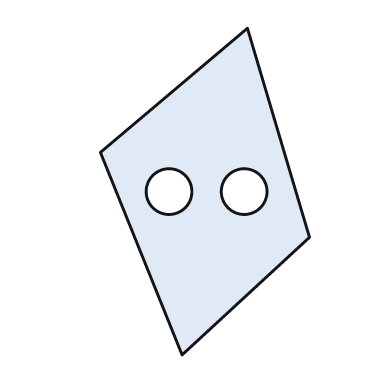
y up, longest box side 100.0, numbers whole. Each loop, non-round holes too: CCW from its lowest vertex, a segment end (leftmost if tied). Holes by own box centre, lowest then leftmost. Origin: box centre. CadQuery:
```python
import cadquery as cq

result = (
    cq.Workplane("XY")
    .moveTo(-7.0, -50.0)
    .lineTo(32.0, -14.0)
    .lineTo(13.0, 50.0)
    .lineTo(-32.0, 12.0)
    .close()
    .moveTo(-11.0, 0.0)
    .circle(7.0)
    .moveTo(12.0, 0.0)
    .circle(7.0)
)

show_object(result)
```